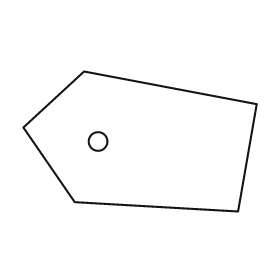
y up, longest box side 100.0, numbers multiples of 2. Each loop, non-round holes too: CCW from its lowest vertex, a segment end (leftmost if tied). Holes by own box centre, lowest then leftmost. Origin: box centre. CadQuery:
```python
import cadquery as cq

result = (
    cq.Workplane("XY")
    .moveTo(42.0, -30.0)
    .lineTo(50.0, 16.0)
    .lineTo(-24.0, 30.0)
    .lineTo(-50.0, 6.0)
    .lineTo(-28.0, -26.0)
    .close()
    .moveTo(-18.0, 0.0)
    .circle(4.0)
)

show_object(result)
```